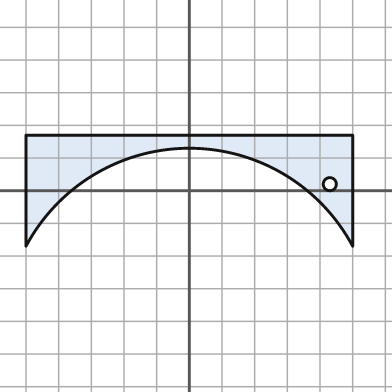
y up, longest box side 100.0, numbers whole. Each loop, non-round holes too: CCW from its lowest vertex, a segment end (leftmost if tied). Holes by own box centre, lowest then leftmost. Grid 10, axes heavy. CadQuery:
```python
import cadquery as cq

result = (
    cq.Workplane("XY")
    .moveTo(-50.0, -17.0)
    .threePointArc((0.0, 13.0), (50.0, -17.0))
    .lineTo(50.0, 17.0)
    .lineTo(-50.0, 17.0)
    .close()
    .moveTo(43.0, 2.0)
    .circle(2.0)
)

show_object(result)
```